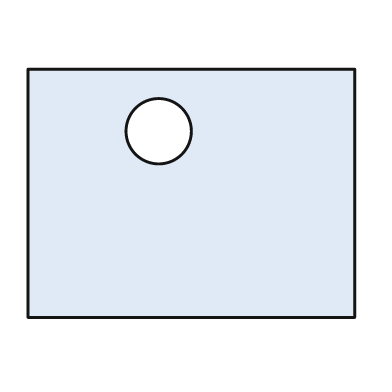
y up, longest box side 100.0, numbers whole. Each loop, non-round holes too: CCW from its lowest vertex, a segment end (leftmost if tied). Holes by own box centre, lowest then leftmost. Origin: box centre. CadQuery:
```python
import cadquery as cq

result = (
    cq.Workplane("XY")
    .moveTo(-50.0, -38.0)
    .lineTo(50.0, -38.0)
    .lineTo(50.0, 38.0)
    .lineTo(-50.0, 38.0)
    .close()
    .moveTo(-10.0, 19.0)
    .circle(10.0)
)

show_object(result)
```